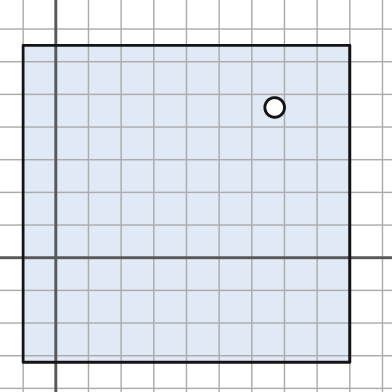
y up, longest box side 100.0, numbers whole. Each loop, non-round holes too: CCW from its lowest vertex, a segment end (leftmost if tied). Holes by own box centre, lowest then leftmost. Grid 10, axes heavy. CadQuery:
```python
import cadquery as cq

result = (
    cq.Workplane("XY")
    .moveTo(-10.0, -32.0)
    .lineTo(90.0, -32.0)
    .lineTo(90.0, 65.0)
    .lineTo(-10.0, 65.0)
    .close()
    .moveTo(67.0, 46.0)
    .circle(3.0)
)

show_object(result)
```